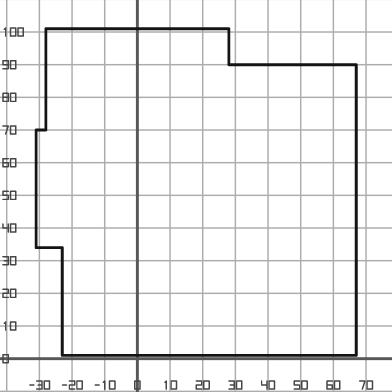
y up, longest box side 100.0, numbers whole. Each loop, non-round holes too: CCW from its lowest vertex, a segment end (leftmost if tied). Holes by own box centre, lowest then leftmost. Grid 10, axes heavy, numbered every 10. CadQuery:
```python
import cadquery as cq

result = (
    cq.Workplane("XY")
    .moveTo(-23.0, 1.0)
    .lineTo(67.0, 1.0)
    .lineTo(67.0, 90.0)
    .lineTo(28.0, 90.0)
    .lineTo(28.0, 101.0)
    .lineTo(-28.0, 101.0)
    .lineTo(-28.0, 70.0)
    .lineTo(-31.0, 70.0)
    .lineTo(-31.0, 34.0)
    .lineTo(-23.0, 34.0)
    .close()
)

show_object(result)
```